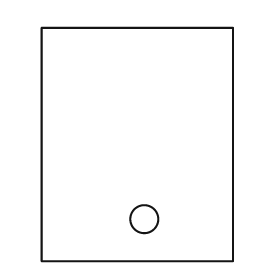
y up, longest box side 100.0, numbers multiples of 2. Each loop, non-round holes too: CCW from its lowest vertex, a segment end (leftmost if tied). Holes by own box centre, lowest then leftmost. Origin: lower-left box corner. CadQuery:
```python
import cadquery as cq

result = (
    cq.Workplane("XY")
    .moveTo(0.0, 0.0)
    .lineTo(82.0, 0.0)
    .lineTo(82.0, 100.0)
    .lineTo(0.0, 100.0)
    .close()
    .moveTo(44.0, 18.0)
    .circle(6.0)
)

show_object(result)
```